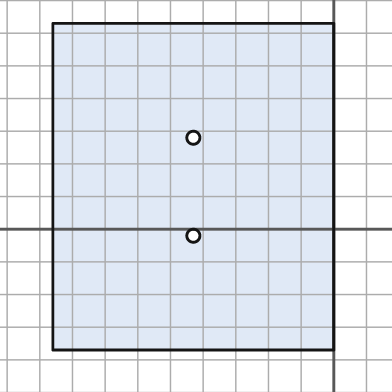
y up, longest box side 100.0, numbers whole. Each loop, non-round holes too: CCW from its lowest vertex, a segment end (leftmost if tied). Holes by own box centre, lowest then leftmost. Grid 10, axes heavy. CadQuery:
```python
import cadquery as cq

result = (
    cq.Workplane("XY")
    .moveTo(-86.0, -37.0)
    .lineTo(0.0, -37.0)
    .lineTo(0.0, 63.0)
    .lineTo(-86.0, 63.0)
    .close()
    .moveTo(-43.0, -2.0)
    .circle(2.0)
    .moveTo(-43.0, 28.0)
    .circle(2.0)
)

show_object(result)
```